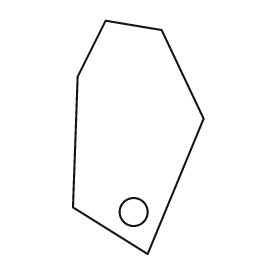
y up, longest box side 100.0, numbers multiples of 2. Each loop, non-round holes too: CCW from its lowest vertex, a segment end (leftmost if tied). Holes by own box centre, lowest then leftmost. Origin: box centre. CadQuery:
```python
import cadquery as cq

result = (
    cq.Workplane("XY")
    .moveTo(4.0, -50.0)
    .lineTo(28.0, 8.0)
    .lineTo(10.0, 46.0)
    .lineTo(-14.0, 50.0)
    .lineTo(-26.0, 26.0)
    .lineTo(-28.0, -30.0)
    .close()
    .moveTo(-2.0, -32.0)
    .circle(6.0)
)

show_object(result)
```